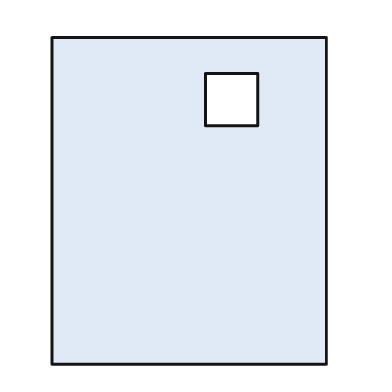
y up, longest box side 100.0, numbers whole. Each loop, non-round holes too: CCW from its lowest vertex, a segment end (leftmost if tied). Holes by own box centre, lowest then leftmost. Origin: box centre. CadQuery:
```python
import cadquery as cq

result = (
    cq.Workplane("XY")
    .moveTo(-42.0, -50.0)
    .lineTo(42.0, -50.0)
    .lineTo(42.0, 50.0)
    .lineTo(-42.0, 50.0)
    .close()
    .moveTo(5.0, 23.0)
    .lineTo(21.0, 23.0)
    .lineTo(21.0, 39.0)
    .lineTo(5.0, 39.0)
    .close()
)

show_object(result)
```